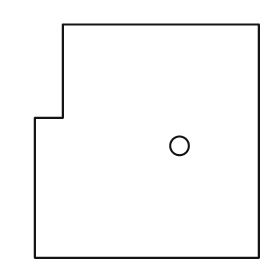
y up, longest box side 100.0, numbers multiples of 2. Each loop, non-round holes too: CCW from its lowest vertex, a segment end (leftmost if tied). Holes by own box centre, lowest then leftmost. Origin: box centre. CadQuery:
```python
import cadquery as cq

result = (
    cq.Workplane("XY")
    .moveTo(-48.0, -50.0)
    .lineTo(48.0, -50.0)
    .lineTo(48.0, 50.0)
    .lineTo(-36.0, 50.0)
    .lineTo(-36.0, 10.0)
    .lineTo(-48.0, 10.0)
    .close()
    .moveTo(14.0, -2.0)
    .circle(4.0)
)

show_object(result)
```